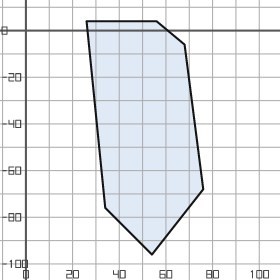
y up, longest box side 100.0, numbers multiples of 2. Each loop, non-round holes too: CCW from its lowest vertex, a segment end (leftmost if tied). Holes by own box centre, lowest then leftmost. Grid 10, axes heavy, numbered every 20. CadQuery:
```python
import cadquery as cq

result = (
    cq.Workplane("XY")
    .moveTo(54.0, -96.0)
    .lineTo(76.0, -68.0)
    .lineTo(68.0, -6.0)
    .lineTo(56.0, 4.0)
    .lineTo(26.0, 4.0)
    .lineTo(34.0, -76.0)
    .close()
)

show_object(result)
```